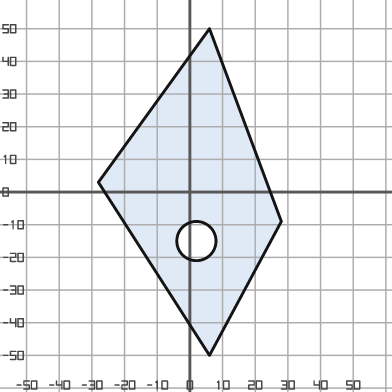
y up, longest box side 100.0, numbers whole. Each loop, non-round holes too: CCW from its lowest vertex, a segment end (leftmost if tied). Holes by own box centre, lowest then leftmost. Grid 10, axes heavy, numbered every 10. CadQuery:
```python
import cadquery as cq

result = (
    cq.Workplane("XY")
    .moveTo(6.0, -50.0)
    .lineTo(28.0, -9.0)
    .lineTo(6.0, 50.0)
    .lineTo(-28.0, 3.0)
    .close()
    .moveTo(2.0, -15.0)
    .circle(6.0)
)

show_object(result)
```